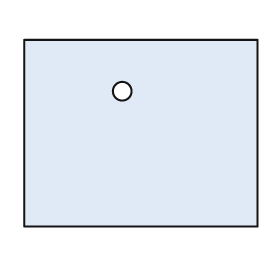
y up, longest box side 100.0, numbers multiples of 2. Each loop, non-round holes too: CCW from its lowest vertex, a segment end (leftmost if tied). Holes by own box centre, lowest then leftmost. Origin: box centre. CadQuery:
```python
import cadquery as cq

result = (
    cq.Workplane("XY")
    .moveTo(-50.0, -40.0)
    .lineTo(50.0, -40.0)
    .lineTo(50.0, 40.0)
    .lineTo(-50.0, 40.0)
    .close()
    .moveTo(-8.0, 18.0)
    .circle(4.0)
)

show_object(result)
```